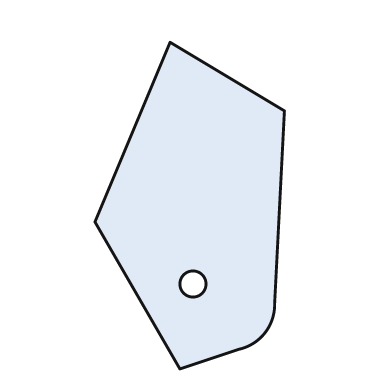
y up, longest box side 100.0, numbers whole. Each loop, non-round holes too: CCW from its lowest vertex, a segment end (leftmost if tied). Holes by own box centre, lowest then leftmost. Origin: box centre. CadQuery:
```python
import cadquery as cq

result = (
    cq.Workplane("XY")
    .moveTo(-3.0, -50.0)
    .lineTo(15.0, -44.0)
    .threePointArc((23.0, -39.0), (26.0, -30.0))
    .lineTo(29.0, 29.0)
    .lineTo(-6.0, 50.0)
    .lineTo(-29.0, -5.0)
    .close()
    .moveTo(1.0, -24.0)
    .circle(4.0)
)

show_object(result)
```